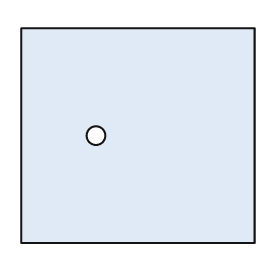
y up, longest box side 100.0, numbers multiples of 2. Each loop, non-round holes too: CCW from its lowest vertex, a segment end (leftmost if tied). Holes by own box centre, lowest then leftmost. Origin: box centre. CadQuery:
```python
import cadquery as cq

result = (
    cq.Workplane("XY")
    .moveTo(-50.0, -46.0)
    .lineTo(50.0, -46.0)
    .lineTo(50.0, 46.0)
    .lineTo(-50.0, 46.0)
    .close()
    .moveTo(-18.0, 0.0)
    .circle(4.0)
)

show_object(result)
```